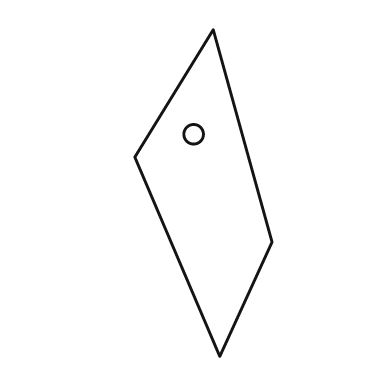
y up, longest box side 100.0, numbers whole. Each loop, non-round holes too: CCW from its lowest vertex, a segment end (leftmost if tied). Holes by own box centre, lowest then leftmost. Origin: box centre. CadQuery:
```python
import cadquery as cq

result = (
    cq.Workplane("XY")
    .moveTo(5.0, -50.0)
    .lineTo(21.0, -15.0)
    .lineTo(3.0, 50.0)
    .lineTo(-21.0, 11.0)
    .close()
    .moveTo(-3.0, 18.0)
    .circle(3.0)
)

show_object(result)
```